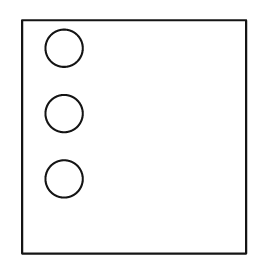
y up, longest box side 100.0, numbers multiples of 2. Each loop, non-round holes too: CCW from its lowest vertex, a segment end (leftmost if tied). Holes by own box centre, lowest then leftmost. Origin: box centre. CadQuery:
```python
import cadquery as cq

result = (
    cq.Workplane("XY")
    .moveTo(-48.0, -50.0)
    .lineTo(48.0, -50.0)
    .lineTo(48.0, 50.0)
    .lineTo(-48.0, 50.0)
    .close()
    .moveTo(-30.0, -18.0)
    .circle(8.0)
    .moveTo(-30.0, 10.0)
    .circle(8.0)
    .moveTo(-30.0, 38.0)
    .circle(8.0)
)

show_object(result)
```